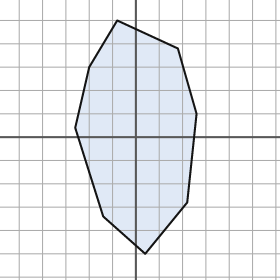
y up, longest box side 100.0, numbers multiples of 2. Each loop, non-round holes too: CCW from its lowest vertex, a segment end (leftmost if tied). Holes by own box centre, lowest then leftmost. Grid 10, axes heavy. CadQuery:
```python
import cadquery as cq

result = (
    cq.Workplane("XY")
    .moveTo(4.0, -50.0)
    .lineTo(22.0, -28.0)
    .lineTo(26.0, 10.0)
    .lineTo(18.0, 38.0)
    .lineTo(-8.0, 50.0)
    .lineTo(-20.0, 30.0)
    .lineTo(-26.0, 4.0)
    .lineTo(-14.0, -34.0)
    .close()
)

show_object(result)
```